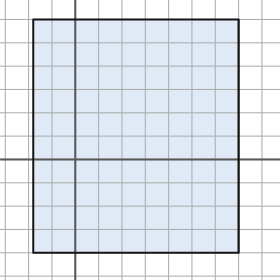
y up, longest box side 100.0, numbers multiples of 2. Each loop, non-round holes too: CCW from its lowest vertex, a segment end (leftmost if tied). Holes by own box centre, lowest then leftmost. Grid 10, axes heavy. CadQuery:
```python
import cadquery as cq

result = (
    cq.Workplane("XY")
    .moveTo(-18.0, -40.0)
    .lineTo(70.0, -40.0)
    .lineTo(70.0, 60.0)
    .lineTo(-18.0, 60.0)
    .close()
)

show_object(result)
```